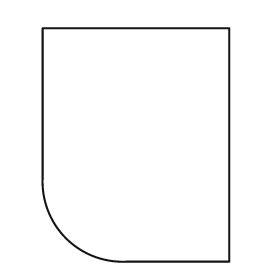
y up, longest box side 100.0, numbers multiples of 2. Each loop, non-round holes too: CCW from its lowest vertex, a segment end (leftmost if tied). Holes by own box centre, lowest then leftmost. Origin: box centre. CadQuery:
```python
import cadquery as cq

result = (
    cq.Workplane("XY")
    .moveTo(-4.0, -50.0)
    .lineTo(40.0, -50.0)
    .lineTo(40.0, 50.0)
    .lineTo(-40.0, 50.0)
    .lineTo(-40.0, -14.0)
    .threePointArc((-30.0, -40.0), (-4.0, -50.0))
    .close()
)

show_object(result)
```